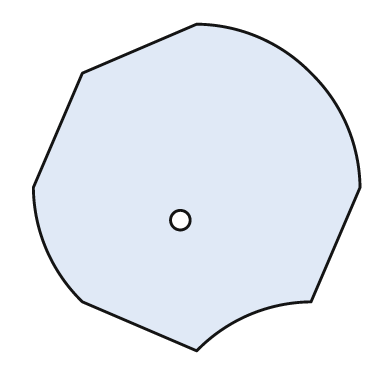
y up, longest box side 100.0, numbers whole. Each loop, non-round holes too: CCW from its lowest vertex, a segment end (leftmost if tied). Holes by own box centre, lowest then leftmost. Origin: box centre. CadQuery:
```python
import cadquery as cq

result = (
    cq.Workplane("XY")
    .moveTo(0.0, -50.0)
    .threePointArc((16.0, -39.0), (35.0, -35.0))
    .lineTo(50.0, 0.0)
    .threePointArc((46.0, 19.0), (35.0, 35.0))
    .threePointArc((19.0, 46.0), (0.0, 50.0))
    .lineTo(-35.0, 35.0)
    .lineTo(-50.0, 0.0)
    .threePointArc((-46.0, -19.0), (-35.0, -35.0))
    .close()
    .moveTo(-5.0, -10.0)
    .circle(3.0)
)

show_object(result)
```